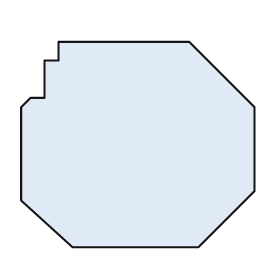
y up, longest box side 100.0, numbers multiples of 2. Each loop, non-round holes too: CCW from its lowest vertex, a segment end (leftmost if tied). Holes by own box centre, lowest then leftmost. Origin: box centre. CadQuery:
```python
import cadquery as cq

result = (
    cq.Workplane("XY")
    .moveTo(-28.0, -44.0)
    .lineTo(26.0, -44.0)
    .lineTo(50.0, -20.0)
    .lineTo(50.0, 16.0)
    .lineTo(22.0, 44.0)
    .lineTo(-34.0, 44.0)
    .lineTo(-34.0, 36.0)
    .lineTo(-40.0, 36.0)
    .lineTo(-40.0, 20.0)
    .lineTo(-46.0, 20.0)
    .lineTo(-50.0, 16.0)
    .lineTo(-50.0, -24.0)
    .close()
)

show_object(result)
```